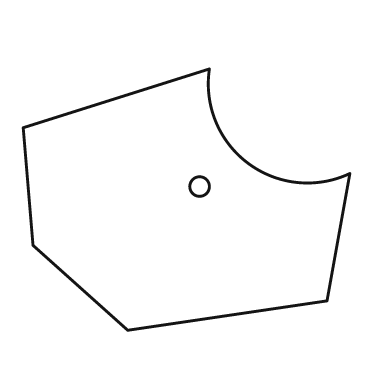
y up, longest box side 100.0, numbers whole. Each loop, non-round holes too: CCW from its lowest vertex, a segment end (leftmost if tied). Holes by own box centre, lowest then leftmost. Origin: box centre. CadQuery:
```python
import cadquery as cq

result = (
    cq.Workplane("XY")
    .moveTo(-18.0, -40.0)
    .lineTo(43.0, -31.0)
    .lineTo(50.0, 8.0)
    .threePointArc((19.0, 11.0), (7.0, 40.0))
    .lineTo(-50.0, 22.0)
    .lineTo(-47.0, -14.0)
    .close()
    .moveTo(4.0, 4.0)
    .circle(3.0)
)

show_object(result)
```